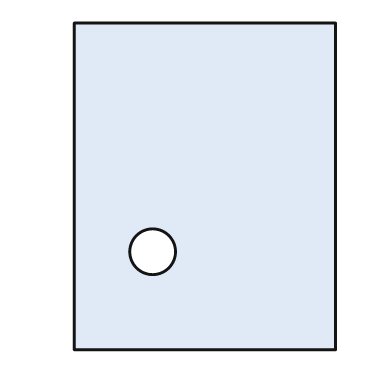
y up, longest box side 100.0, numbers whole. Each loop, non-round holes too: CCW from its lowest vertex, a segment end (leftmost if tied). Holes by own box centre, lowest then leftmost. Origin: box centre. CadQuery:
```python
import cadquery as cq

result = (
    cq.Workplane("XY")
    .moveTo(-40.0, -50.0)
    .lineTo(40.0, -50.0)
    .lineTo(40.0, 50.0)
    .lineTo(-40.0, 50.0)
    .close()
    .moveTo(-16.0, -20.0)
    .circle(7.0)
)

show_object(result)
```